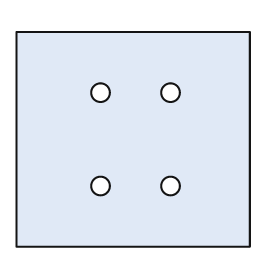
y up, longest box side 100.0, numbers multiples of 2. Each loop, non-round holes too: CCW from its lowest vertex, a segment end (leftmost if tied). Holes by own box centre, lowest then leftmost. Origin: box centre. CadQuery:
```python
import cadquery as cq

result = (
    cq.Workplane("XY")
    .moveTo(-50.0, -46.0)
    .lineTo(50.0, -46.0)
    .lineTo(50.0, 46.0)
    .lineTo(-50.0, 46.0)
    .close()
    .moveTo(-14.0, -20.0)
    .circle(4.0)
    .moveTo(16.0, -20.0)
    .circle(4.0)
    .moveTo(-14.0, 20.0)
    .circle(4.0)
    .moveTo(16.0, 20.0)
    .circle(4.0)
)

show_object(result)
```